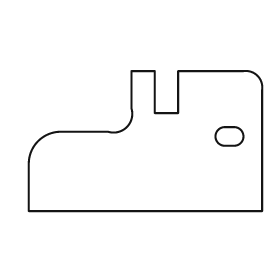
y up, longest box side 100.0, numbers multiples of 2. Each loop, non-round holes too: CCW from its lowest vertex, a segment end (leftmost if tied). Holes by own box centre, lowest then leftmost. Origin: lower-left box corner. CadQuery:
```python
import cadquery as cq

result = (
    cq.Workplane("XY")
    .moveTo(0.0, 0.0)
    .lineTo(100.0, 0.0)
    .lineTo(100.0, 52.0)
    .threePointArc((98.0, 58.0), (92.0, 60.0))
    .lineTo(64.0, 60.0)
    .lineTo(64.0, 42.0)
    .lineTo(54.0, 42.0)
    .lineTo(54.0, 60.0)
    .lineTo(44.0, 60.0)
    .lineTo(44.0, 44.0)
    .threePointArc((42.0, 36.0), (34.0, 34.0))
    .lineTo(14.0, 34.0)
    .threePointArc((4.0, 30.0), (0.0, 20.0))
    .close()
    .moveTo(84.0, 28.0)
    .lineTo(88.0, 28.0)
    .threePointArc((92.0, 32.0), (88.0, 36.0))
    .lineTo(84.0, 36.0)
    .threePointArc((80.0, 32.0), (84.0, 28.0))
    .close()
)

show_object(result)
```